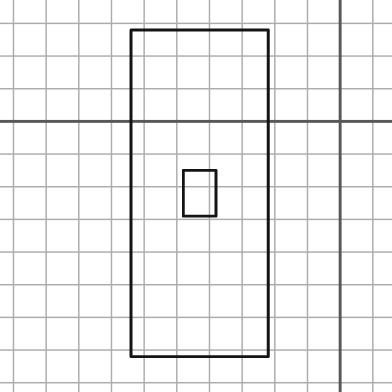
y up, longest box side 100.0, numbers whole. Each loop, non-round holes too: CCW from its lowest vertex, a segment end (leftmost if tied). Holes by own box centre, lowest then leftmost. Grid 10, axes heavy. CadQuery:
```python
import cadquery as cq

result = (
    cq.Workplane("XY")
    .moveTo(-64.0, -72.0)
    .lineTo(-22.0, -72.0)
    .lineTo(-22.0, 28.0)
    .lineTo(-64.0, 28.0)
    .close()
    .moveTo(-48.0, -29.0)
    .lineTo(-38.0, -29.0)
    .lineTo(-38.0, -15.0)
    .lineTo(-48.0, -15.0)
    .close()
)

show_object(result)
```